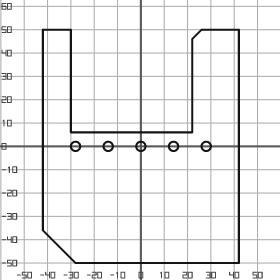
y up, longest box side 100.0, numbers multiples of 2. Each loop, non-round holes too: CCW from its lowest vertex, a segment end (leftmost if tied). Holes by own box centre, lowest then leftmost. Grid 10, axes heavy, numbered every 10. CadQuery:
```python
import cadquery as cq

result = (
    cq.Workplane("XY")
    .moveTo(-28.0, -50.0)
    .lineTo(42.0, -50.0)
    .lineTo(42.0, 50.0)
    .lineTo(26.0, 50.0)
    .lineTo(22.0, 46.0)
    .lineTo(22.0, 6.0)
    .lineTo(-30.0, 6.0)
    .lineTo(-30.0, 50.0)
    .lineTo(-42.0, 50.0)
    .lineTo(-42.0, -36.0)
    .close()
    .moveTo(-28.0, 0.0)
    .circle(2.0)
    .moveTo(-14.0, 0.0)
    .circle(2.0)
    .moveTo(0.0, 0.0)
    .circle(2.0)
    .moveTo(14.0, 0.0)
    .circle(2.0)
    .moveTo(28.0, 0.0)
    .circle(2.0)
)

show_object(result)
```